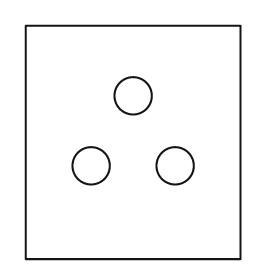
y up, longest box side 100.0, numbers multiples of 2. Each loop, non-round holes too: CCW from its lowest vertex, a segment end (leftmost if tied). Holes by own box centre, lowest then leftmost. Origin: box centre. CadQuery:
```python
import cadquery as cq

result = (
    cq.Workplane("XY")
    .moveTo(-46.0, -50.0)
    .lineTo(46.0, -50.0)
    .lineTo(46.0, 50.0)
    .lineTo(-46.0, 50.0)
    .close()
    .moveTo(-18.0, -10.0)
    .circle(8.0)
    .moveTo(18.0, -10.0)
    .circle(8.0)
    .moveTo(0.0, 20.0)
    .circle(8.0)
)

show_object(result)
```